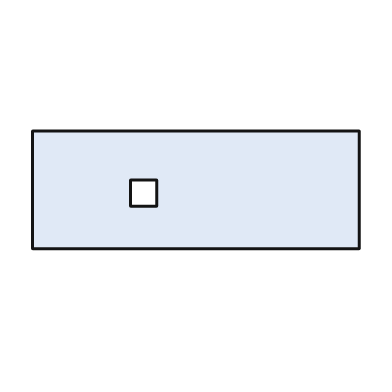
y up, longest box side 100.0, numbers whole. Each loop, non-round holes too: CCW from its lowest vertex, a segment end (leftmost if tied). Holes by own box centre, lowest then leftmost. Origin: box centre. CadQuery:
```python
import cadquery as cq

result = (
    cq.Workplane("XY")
    .moveTo(-50.0, -18.0)
    .lineTo(50.0, -18.0)
    .lineTo(50.0, 18.0)
    .lineTo(-50.0, 18.0)
    .close()
    .moveTo(-20.0, -5.0)
    .lineTo(-12.0, -5.0)
    .lineTo(-12.0, 3.0)
    .lineTo(-20.0, 3.0)
    .close()
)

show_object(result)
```